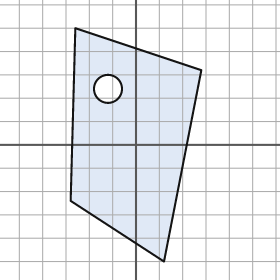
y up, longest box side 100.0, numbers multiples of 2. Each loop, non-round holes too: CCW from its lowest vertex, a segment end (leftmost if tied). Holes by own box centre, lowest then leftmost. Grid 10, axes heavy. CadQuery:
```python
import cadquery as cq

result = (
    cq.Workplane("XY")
    .moveTo(12.0, -50.0)
    .lineTo(28.0, 32.0)
    .lineTo(-26.0, 50.0)
    .lineTo(-28.0, -24.0)
    .close()
    .moveTo(-12.0, 24.0)
    .circle(6.0)
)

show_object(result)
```